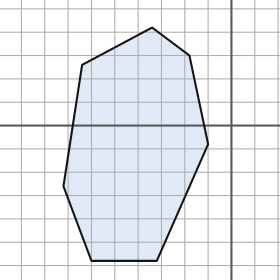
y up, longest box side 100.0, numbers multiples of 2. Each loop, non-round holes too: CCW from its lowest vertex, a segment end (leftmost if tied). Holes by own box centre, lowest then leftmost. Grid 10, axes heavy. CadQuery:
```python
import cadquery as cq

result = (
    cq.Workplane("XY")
    .moveTo(-60.0, -58.0)
    .lineTo(-32.0, -58.0)
    .lineTo(-10.0, -8.0)
    .lineTo(-18.0, 30.0)
    .lineTo(-34.0, 42.0)
    .lineTo(-64.0, 26.0)
    .lineTo(-72.0, -26.0)
    .close()
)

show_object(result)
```